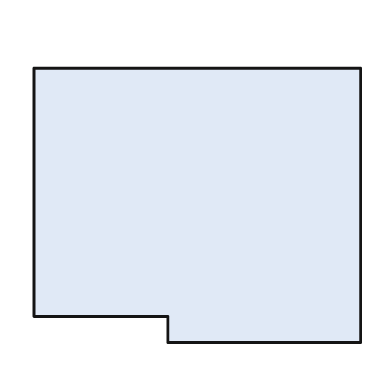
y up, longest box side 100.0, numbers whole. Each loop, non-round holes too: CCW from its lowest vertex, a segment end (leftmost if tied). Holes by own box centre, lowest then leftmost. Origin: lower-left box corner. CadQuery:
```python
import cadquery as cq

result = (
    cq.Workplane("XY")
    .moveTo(41.0, 0.0)
    .lineTo(100.0, 0.0)
    .lineTo(100.0, 84.0)
    .lineTo(0.0, 84.0)
    .lineTo(0.0, 8.0)
    .lineTo(41.0, 8.0)
    .close()
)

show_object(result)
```